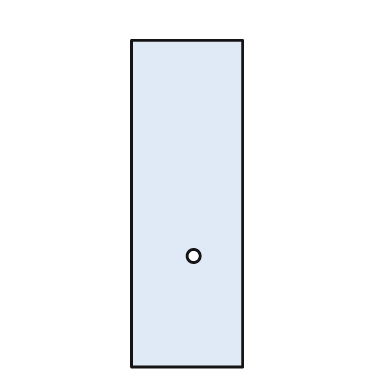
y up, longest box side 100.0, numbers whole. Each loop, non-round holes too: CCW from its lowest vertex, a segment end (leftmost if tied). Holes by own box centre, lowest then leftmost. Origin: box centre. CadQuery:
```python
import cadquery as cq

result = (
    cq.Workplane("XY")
    .moveTo(-17.0, -50.0)
    .lineTo(17.0, -50.0)
    .lineTo(17.0, 50.0)
    .lineTo(-17.0, 50.0)
    .close()
    .moveTo(2.0, -16.0)
    .circle(2.0)
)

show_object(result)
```